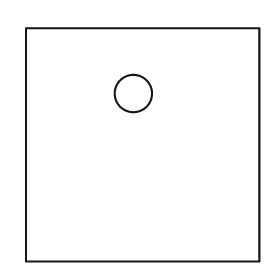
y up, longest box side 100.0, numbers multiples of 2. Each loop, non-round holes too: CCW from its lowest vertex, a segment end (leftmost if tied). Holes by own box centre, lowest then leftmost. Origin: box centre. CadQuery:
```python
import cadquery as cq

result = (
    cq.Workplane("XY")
    .moveTo(-50.0, -50.0)
    .lineTo(50.0, -50.0)
    .lineTo(50.0, 50.0)
    .lineTo(-50.0, 50.0)
    .close()
    .moveTo(-4.0, 22.0)
    .circle(8.0)
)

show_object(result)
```